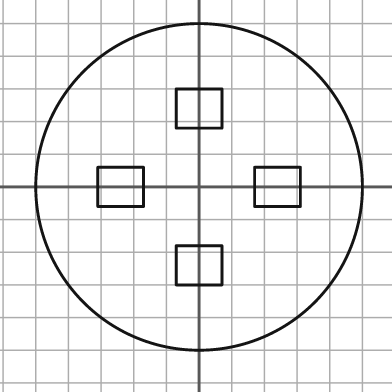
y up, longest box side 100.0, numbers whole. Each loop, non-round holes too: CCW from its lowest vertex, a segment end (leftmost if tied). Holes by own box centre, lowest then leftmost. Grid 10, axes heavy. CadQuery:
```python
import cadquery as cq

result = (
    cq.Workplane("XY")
    .moveTo(0.0, 0.0)
    .circle(50.0)
    .moveTo(-7.0, -30.0)
    .lineTo(7.0, -30.0)
    .lineTo(7.0, -18.0)
    .lineTo(-7.0, -18.0)
    .close()
    .moveTo(-31.0, -6.0)
    .lineTo(-17.0, -6.0)
    .lineTo(-17.0, 6.0)
    .lineTo(-31.0, 6.0)
    .close()
    .moveTo(17.0, -6.0)
    .lineTo(31.0, -6.0)
    .lineTo(31.0, 6.0)
    .lineTo(17.0, 6.0)
    .close()
    .moveTo(-7.0, 18.0)
    .lineTo(7.0, 18.0)
    .lineTo(7.0, 30.0)
    .lineTo(-7.0, 30.0)
    .close()
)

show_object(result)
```